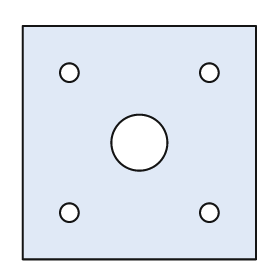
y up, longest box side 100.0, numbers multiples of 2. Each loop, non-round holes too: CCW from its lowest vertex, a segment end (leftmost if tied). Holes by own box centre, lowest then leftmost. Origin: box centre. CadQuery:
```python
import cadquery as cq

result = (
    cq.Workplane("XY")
    .moveTo(-50.0, -50.0)
    .lineTo(50.0, -50.0)
    .lineTo(50.0, 50.0)
    .lineTo(-50.0, 50.0)
    .close()
    .moveTo(-30.0, -30.0)
    .circle(4.0)
    .moveTo(30.0, -30.0)
    .circle(4.0)
    .moveTo(0.0, 0.0)
    .circle(12.0)
    .moveTo(-30.0, 30.0)
    .circle(4.0)
    .moveTo(30.0, 30.0)
    .circle(4.0)
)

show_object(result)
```